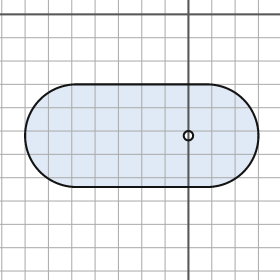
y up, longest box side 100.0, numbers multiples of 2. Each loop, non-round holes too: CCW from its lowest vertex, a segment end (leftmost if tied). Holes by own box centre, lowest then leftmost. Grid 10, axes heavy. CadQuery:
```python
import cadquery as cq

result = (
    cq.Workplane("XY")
    .moveTo(-48.0, -74.0)
    .lineTo(8.0, -74.0)
    .threePointArc((30.0, -52.0), (8.0, -30.0))
    .lineTo(-48.0, -30.0)
    .threePointArc((-70.0, -52.0), (-48.0, -74.0))
    .close()
    .moveTo(0.0, -52.0)
    .circle(2.0)
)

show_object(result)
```